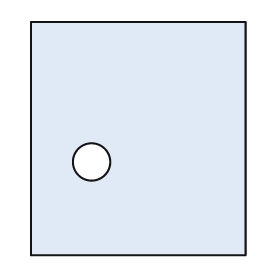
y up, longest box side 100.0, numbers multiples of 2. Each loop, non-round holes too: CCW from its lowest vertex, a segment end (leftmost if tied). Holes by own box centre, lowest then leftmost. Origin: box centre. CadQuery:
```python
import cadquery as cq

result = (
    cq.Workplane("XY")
    .moveTo(-46.0, -50.0)
    .lineTo(46.0, -50.0)
    .lineTo(46.0, 50.0)
    .lineTo(-46.0, 50.0)
    .close()
    .moveTo(-20.0, -10.0)
    .circle(8.0)
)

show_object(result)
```